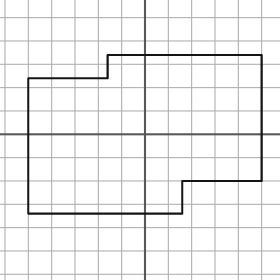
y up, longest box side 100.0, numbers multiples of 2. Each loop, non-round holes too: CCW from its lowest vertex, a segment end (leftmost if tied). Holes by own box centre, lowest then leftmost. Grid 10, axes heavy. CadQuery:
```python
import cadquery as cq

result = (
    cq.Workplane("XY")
    .moveTo(-50.0, -34.0)
    .lineTo(16.0, -34.0)
    .lineTo(16.0, -20.0)
    .lineTo(50.0, -20.0)
    .lineTo(50.0, 34.0)
    .lineTo(-16.0, 34.0)
    .lineTo(-16.0, 24.0)
    .lineTo(-50.0, 24.0)
    .close()
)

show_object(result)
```